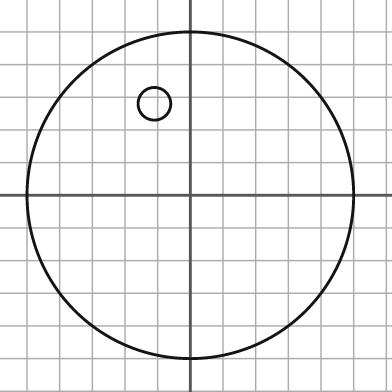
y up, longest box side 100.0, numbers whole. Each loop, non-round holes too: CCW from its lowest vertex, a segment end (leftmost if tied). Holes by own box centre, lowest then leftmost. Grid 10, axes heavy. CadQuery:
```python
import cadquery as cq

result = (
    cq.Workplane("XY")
    .moveTo(0.0, 0.0)
    .circle(50.0)
    .moveTo(-11.0, 28.0)
    .circle(5.0)
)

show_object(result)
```